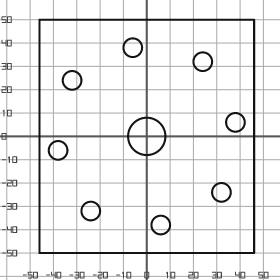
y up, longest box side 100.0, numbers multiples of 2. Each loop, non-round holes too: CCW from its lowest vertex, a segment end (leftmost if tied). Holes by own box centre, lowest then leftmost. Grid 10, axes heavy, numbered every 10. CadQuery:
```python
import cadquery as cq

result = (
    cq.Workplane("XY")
    .moveTo(-46.0, -50.0)
    .lineTo(46.0, -50.0)
    .lineTo(46.0, 50.0)
    .lineTo(-46.0, 50.0)
    .close()
    .moveTo(6.0, -38.0)
    .circle(4.0)
    .moveTo(-24.0, -32.0)
    .circle(4.0)
    .moveTo(32.0, -24.0)
    .circle(4.0)
    .moveTo(-38.0, -6.0)
    .circle(4.0)
    .moveTo(0.0, 0.0)
    .circle(8.0)
    .moveTo(38.0, 6.0)
    .circle(4.0)
    .moveTo(-32.0, 24.0)
    .circle(4.0)
    .moveTo(24.0, 32.0)
    .circle(4.0)
    .moveTo(-6.0, 38.0)
    .circle(4.0)
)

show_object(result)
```